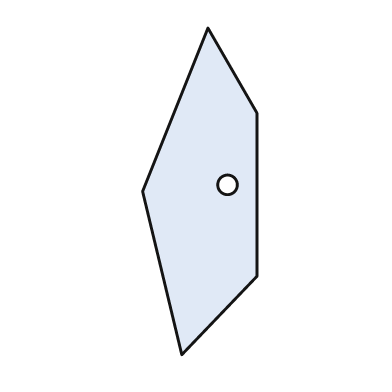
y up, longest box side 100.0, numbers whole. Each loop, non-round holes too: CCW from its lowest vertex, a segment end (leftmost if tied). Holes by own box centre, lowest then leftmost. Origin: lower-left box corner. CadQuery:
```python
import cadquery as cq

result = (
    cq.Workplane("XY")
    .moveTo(12.0, 0.0)
    .lineTo(35.0, 24.0)
    .lineTo(35.0, 74.0)
    .lineTo(20.0, 100.0)
    .lineTo(0.0, 50.0)
    .close()
    .moveTo(26.0, 52.0)
    .circle(3.0)
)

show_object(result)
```